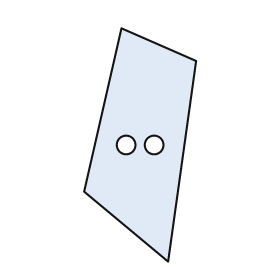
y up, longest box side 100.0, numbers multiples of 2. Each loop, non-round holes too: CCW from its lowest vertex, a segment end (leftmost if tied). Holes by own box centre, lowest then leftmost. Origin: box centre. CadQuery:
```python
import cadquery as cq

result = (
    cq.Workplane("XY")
    .moveTo(12.0, -50.0)
    .lineTo(24.0, 36.0)
    .lineTo(-8.0, 50.0)
    .lineTo(-24.0, -20.0)
    .close()
    .moveTo(-6.0, 0.0)
    .circle(4.0)
    .moveTo(6.0, 0.0)
    .circle(4.0)
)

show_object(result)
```